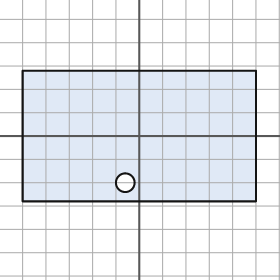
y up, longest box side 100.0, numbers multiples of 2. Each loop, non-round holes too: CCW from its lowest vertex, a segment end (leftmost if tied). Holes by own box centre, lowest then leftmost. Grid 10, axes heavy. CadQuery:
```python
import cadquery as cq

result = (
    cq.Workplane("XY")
    .moveTo(-50.0, -28.0)
    .lineTo(50.0, -28.0)
    .lineTo(50.0, 28.0)
    .lineTo(-50.0, 28.0)
    .close()
    .moveTo(-6.0, -20.0)
    .circle(4.0)
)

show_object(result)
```